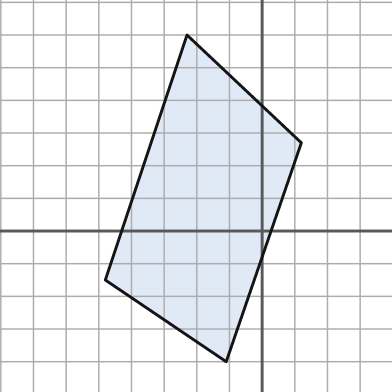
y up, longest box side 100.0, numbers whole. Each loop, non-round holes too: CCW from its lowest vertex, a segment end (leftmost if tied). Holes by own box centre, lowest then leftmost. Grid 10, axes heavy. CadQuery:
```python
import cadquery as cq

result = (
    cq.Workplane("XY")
    .moveTo(-11.0, -40.0)
    .lineTo(12.0, 27.0)
    .lineTo(-23.0, 60.0)
    .lineTo(-48.0, -15.0)
    .close()
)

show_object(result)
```